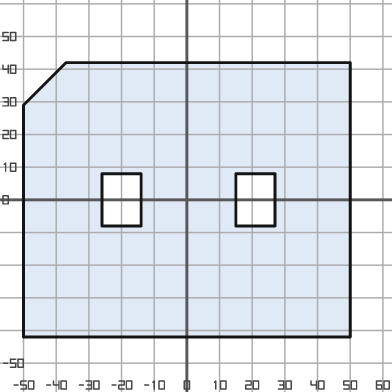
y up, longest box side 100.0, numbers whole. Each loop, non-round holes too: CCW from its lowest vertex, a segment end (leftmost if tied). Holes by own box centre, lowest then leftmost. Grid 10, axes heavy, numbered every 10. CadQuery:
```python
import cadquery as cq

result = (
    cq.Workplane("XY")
    .moveTo(-50.0, -42.0)
    .lineTo(50.0, -42.0)
    .lineTo(50.0, 42.0)
    .lineTo(-37.0, 42.0)
    .lineTo(-50.0, 29.0)
    .close()
    .moveTo(-26.0, -8.0)
    .lineTo(-14.0, -8.0)
    .lineTo(-14.0, 8.0)
    .lineTo(-26.0, 8.0)
    .close()
    .moveTo(15.0, -8.0)
    .lineTo(27.0, -8.0)
    .lineTo(27.0, 8.0)
    .lineTo(15.0, 8.0)
    .close()
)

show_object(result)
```